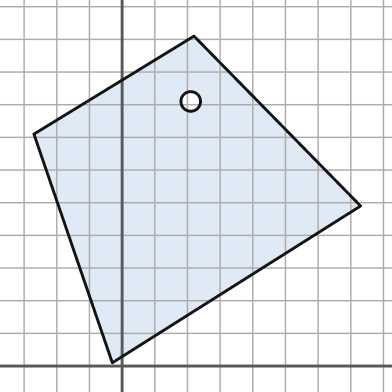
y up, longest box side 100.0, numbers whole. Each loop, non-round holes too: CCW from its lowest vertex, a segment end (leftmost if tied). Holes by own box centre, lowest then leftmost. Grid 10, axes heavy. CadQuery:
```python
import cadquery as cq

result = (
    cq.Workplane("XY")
    .moveTo(-3.0, 1.0)
    .lineTo(73.0, 49.0)
    .lineTo(22.0, 101.0)
    .lineTo(-27.0, 71.0)
    .close()
    .moveTo(21.0, 81.0)
    .circle(3.0)
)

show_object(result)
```